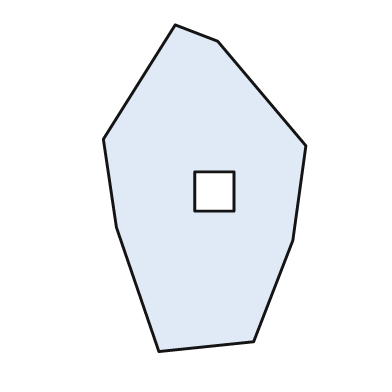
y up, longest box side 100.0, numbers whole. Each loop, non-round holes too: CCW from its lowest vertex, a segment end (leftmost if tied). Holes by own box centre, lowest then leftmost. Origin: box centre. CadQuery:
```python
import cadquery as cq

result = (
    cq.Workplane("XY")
    .moveTo(-14.0, -50.0)
    .lineTo(15.0, -47.0)
    .lineTo(27.0, -16.0)
    .lineTo(31.0, 13.0)
    .lineTo(4.0, 45.0)
    .lineTo(-9.0, 50.0)
    .lineTo(-31.0, 15.0)
    .lineTo(-27.0, -12.0)
    .close()
    .moveTo(-3.0, -7.0)
    .lineTo(9.0, -7.0)
    .lineTo(9.0, 5.0)
    .lineTo(-3.0, 5.0)
    .close()
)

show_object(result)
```